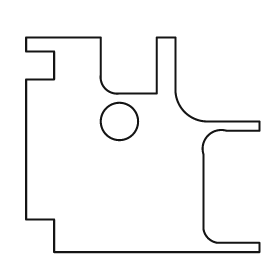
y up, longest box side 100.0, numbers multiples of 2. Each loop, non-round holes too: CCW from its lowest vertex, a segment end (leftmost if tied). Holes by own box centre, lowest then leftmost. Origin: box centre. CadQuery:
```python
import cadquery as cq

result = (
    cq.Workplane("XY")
    .moveTo(-38.0, -46.0)
    .lineTo(50.0, -46.0)
    .lineTo(50.0, -42.0)
    .lineTo(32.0, -42.0)
    .threePointArc((28.0, -40.0), (26.0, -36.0))
    .lineTo(26.0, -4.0)
    .threePointArc((28.0, 4.0), (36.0, 6.0))
    .lineTo(50.0, 6.0)
    .lineTo(50.0, 10.0)
    .lineTo(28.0, 10.0)
    .threePointArc((18.0, 14.0), (14.0, 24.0))
    .lineTo(14.0, 46.0)
    .lineTo(6.0, 46.0)
    .lineTo(6.0, 22.0)
    .lineTo(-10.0, 22.0)
    .threePointArc((-16.0, 24.0), (-18.0, 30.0))
    .lineTo(-18.0, 46.0)
    .lineTo(-50.0, 46.0)
    .lineTo(-50.0, 40.0)
    .lineTo(-38.0, 40.0)
    .lineTo(-38.0, 28.0)
    .lineTo(-50.0, 28.0)
    .lineTo(-50.0, -32.0)
    .lineTo(-38.0, -32.0)
    .close()
    .moveTo(-10.0, 10.0)
    .circle(8.0)
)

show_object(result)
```